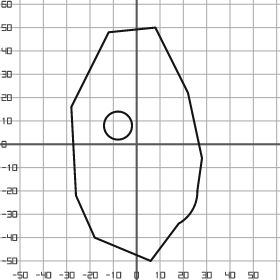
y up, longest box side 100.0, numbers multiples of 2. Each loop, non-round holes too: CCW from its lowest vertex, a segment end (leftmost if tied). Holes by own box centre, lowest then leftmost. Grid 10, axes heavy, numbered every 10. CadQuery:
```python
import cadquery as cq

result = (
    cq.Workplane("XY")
    .moveTo(6.0, -50.0)
    .lineTo(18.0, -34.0)
    .threePointArc((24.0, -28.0), (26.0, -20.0))
    .lineTo(28.0, -6.0)
    .lineTo(22.0, 22.0)
    .lineTo(8.0, 50.0)
    .lineTo(-12.0, 48.0)
    .lineTo(-28.0, 16.0)
    .lineTo(-26.0, -22.0)
    .lineTo(-18.0, -40.0)
    .close()
    .moveTo(-8.0, 8.0)
    .circle(6.0)
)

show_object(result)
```